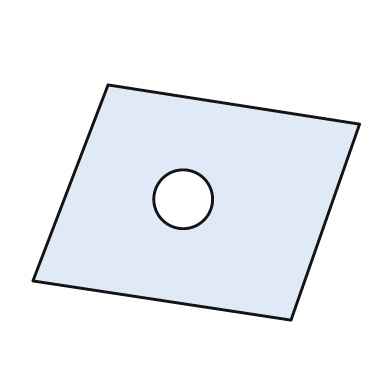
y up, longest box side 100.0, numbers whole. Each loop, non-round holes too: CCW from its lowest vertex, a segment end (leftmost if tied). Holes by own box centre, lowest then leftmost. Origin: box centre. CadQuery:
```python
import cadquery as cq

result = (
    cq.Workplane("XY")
    .moveTo(29.0, -36.0)
    .lineTo(50.0, 24.0)
    .lineTo(-27.0, 36.0)
    .lineTo(-50.0, -24.0)
    .close()
    .moveTo(-4.0, 1.0)
    .circle(9.0)
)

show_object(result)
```